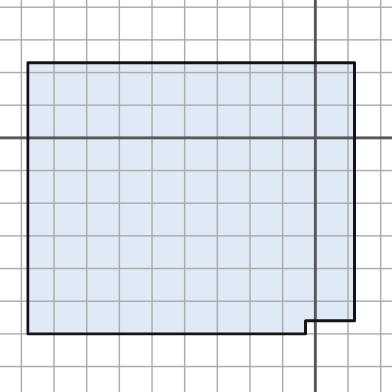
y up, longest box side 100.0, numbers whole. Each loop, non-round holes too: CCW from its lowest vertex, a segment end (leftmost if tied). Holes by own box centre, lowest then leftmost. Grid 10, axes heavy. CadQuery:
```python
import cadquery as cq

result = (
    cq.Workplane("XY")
    .moveTo(-88.0, -60.0)
    .lineTo(-3.0, -60.0)
    .lineTo(-3.0, -56.0)
    .lineTo(12.0, -56.0)
    .lineTo(12.0, 23.0)
    .lineTo(-88.0, 23.0)
    .close()
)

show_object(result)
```